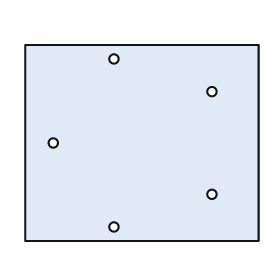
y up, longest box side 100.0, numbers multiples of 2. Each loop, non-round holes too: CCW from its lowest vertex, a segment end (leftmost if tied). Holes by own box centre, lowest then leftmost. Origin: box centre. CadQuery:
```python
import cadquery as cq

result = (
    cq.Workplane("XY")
    .moveTo(-50.0, -42.0)
    .lineTo(50.0, -42.0)
    .lineTo(50.0, 42.0)
    .lineTo(-50.0, 42.0)
    .close()
    .moveTo(-12.0, -36.0)
    .circle(2.0)
    .moveTo(30.0, -22.0)
    .circle(2.0)
    .moveTo(-38.0, 0.0)
    .circle(2.0)
    .moveTo(30.0, 22.0)
    .circle(2.0)
    .moveTo(-12.0, 36.0)
    .circle(2.0)
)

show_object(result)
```